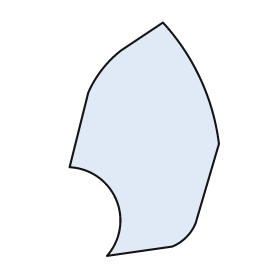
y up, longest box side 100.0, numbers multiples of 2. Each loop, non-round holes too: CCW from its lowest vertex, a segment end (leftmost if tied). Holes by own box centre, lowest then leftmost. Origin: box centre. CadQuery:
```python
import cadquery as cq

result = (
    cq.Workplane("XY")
    .moveTo(-16.0, -50.0)
    .lineTo(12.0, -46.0)
    .threePointArc((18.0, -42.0), (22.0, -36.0))
    .lineTo(32.0, -2.0)
    .threePointArc((24.0, 26.0), (8.0, 50.0))
    .lineTo(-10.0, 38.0)
    .threePointArc((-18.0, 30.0), (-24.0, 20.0))
    .lineTo(-32.0, -12.0)
    .threePointArc((-12.0, -26.0), (-16.0, -50.0))
    .close()
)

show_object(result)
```